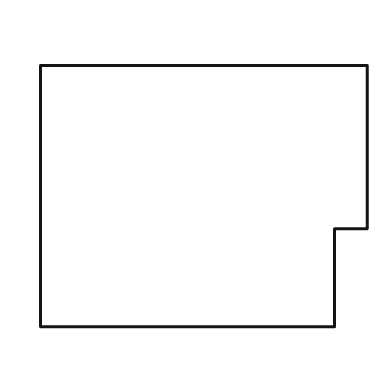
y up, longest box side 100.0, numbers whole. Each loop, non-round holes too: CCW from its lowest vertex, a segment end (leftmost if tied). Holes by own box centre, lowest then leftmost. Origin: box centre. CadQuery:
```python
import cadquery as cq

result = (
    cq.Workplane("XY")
    .moveTo(-50.0, -40.0)
    .lineTo(40.0, -40.0)
    .lineTo(40.0, -10.0)
    .lineTo(50.0, -10.0)
    .lineTo(50.0, 40.0)
    .lineTo(-50.0, 40.0)
    .close()
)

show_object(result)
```